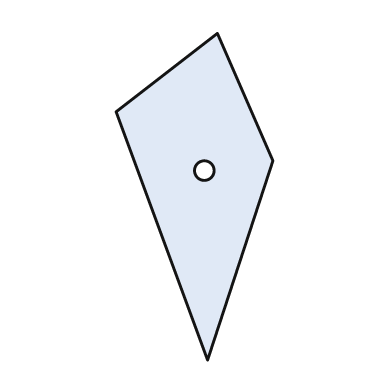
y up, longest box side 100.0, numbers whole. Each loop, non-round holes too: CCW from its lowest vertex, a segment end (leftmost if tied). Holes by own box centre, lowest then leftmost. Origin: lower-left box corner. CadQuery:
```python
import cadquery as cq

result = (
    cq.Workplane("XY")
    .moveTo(28.0, 0.0)
    .lineTo(48.0, 61.0)
    .lineTo(31.0, 100.0)
    .lineTo(0.0, 76.0)
    .close()
    .moveTo(27.0, 58.0)
    .circle(3.0)
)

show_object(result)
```